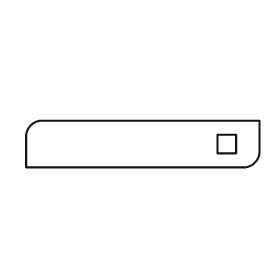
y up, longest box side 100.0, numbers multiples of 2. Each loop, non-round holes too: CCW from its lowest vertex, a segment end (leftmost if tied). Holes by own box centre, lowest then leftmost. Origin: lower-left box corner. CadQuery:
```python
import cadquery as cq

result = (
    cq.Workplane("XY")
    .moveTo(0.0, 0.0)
    .lineTo(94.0, 0.0)
    .threePointArc((98.0, 2.0), (100.0, 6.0))
    .lineTo(100.0, 20.0)
    .lineTo(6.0, 20.0)
    .threePointArc((2.0, 18.0), (0.0, 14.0))
    .close()
    .moveTo(82.0, 6.0)
    .lineTo(90.0, 6.0)
    .lineTo(90.0, 14.0)
    .lineTo(82.0, 14.0)
    .close()
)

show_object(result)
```